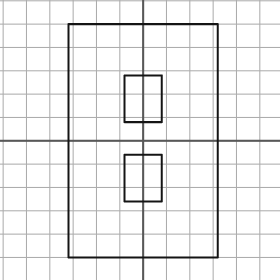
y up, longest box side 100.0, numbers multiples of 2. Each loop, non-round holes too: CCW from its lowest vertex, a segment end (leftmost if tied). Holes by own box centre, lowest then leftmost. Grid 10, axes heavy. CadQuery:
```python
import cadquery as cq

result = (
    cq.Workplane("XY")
    .moveTo(-32.0, -50.0)
    .lineTo(32.0, -50.0)
    .lineTo(32.0, 50.0)
    .lineTo(-32.0, 50.0)
    .close()
    .moveTo(-8.0, -26.0)
    .lineTo(8.0, -26.0)
    .lineTo(8.0, -6.0)
    .lineTo(-8.0, -6.0)
    .close()
    .moveTo(-8.0, 8.0)
    .lineTo(8.0, 8.0)
    .lineTo(8.0, 28.0)
    .lineTo(-8.0, 28.0)
    .close()
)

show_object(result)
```